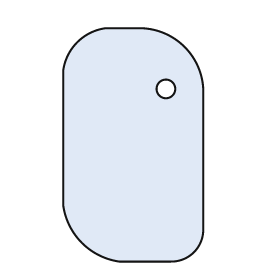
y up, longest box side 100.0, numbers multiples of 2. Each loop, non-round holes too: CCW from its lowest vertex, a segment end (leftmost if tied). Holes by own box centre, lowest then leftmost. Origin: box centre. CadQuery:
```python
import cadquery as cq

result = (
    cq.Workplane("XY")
    .moveTo(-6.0, -50.0)
    .lineTo(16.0, -50.0)
    .threePointArc((26.0, -46.0), (30.0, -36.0))
    .lineTo(30.0, 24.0)
    .threePointArc((22.0, 42.0), (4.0, 50.0))
    .lineTo(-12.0, 50.0)
    .threePointArc((-24.0, 44.0), (-30.0, 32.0))
    .lineTo(-30.0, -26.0)
    .threePointArc((-22.0, -42.0), (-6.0, -50.0))
    .close()
    .moveTo(14.0, 24.0)
    .circle(4.0)
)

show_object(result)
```